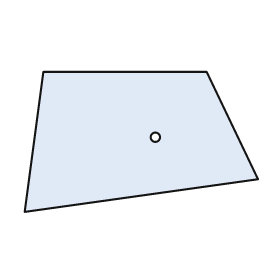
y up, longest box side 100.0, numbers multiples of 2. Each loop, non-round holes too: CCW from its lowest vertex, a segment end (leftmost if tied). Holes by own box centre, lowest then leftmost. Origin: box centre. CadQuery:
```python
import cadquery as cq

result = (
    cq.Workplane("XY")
    .moveTo(-50.0, -30.0)
    .lineTo(50.0, -16.0)
    .lineTo(28.0, 30.0)
    .lineTo(-42.0, 30.0)
    .close()
    .moveTo(6.0, 2.0)
    .circle(2.0)
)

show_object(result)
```